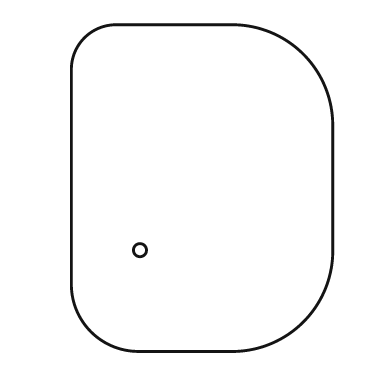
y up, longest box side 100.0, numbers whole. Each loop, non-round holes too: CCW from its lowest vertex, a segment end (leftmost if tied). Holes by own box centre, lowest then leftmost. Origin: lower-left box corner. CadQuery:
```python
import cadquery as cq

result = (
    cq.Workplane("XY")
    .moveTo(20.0, 0.0)
    .lineTo(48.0, 0.0)
    .threePointArc((71.0, 9.0), (80.0, 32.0))
    .lineTo(80.0, 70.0)
    .threePointArc((71.0, 91.0), (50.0, 100.0))
    .lineTo(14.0, 100.0)
    .threePointArc((4.0, 96.0), (0.0, 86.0))
    .lineTo(0.0, 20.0)
    .threePointArc((6.0, 6.0), (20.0, 0.0))
    .close()
    .moveTo(21.0, 31.0)
    .circle(2.0)
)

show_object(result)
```